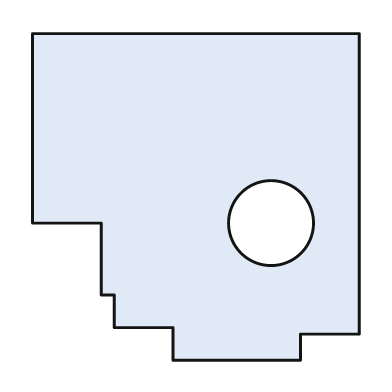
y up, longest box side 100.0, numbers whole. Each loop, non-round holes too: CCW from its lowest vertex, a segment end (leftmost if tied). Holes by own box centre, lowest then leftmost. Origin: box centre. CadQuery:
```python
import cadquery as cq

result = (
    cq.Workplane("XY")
    .moveTo(-7.0, -50.0)
    .lineTo(32.0, -50.0)
    .lineTo(32.0, -42.0)
    .lineTo(50.0, -42.0)
    .lineTo(50.0, 50.0)
    .lineTo(-50.0, 50.0)
    .lineTo(-50.0, -8.0)
    .lineTo(-29.0, -8.0)
    .lineTo(-29.0, -30.0)
    .lineTo(-25.0, -30.0)
    .lineTo(-25.0, -40.0)
    .lineTo(-7.0, -40.0)
    .close()
    .moveTo(23.0, -8.0)
    .circle(13.0)
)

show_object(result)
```